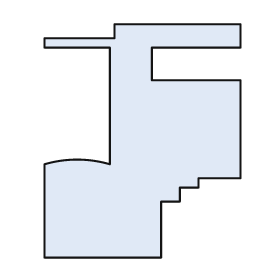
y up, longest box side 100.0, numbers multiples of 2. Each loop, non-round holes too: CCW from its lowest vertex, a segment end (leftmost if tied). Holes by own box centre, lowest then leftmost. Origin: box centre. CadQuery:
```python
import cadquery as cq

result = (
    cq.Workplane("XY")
    .moveTo(-42.0, -50.0)
    .lineTo(8.0, -50.0)
    .lineTo(8.0, -26.0)
    .lineTo(16.0, -26.0)
    .lineTo(16.0, -20.0)
    .lineTo(24.0, -20.0)
    .lineTo(24.0, -16.0)
    .lineTo(42.0, -16.0)
    .lineTo(42.0, 26.0)
    .lineTo(4.0, 26.0)
    .lineTo(4.0, 40.0)
    .lineTo(42.0, 40.0)
    .lineTo(42.0, 50.0)
    .lineTo(-12.0, 50.0)
    .lineTo(-12.0, 44.0)
    .lineTo(-42.0, 44.0)
    .lineTo(-42.0, 40.0)
    .lineTo(-14.0, 40.0)
    .lineTo(-14.0, -10.0)
    .threePointArc((-28.0, -8.0), (-42.0, -10.0))
    .close()
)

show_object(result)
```